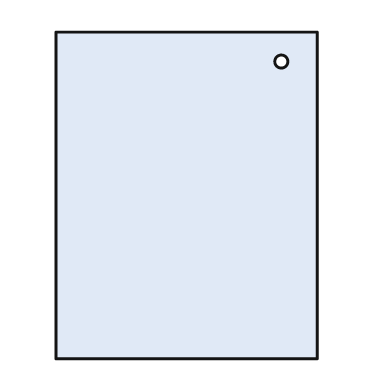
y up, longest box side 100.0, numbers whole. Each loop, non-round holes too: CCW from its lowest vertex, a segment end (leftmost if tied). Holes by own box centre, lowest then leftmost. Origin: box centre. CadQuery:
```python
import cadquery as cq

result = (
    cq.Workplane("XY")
    .moveTo(-40.0, -50.0)
    .lineTo(40.0, -50.0)
    .lineTo(40.0, 50.0)
    .lineTo(-40.0, 50.0)
    .close()
    .moveTo(29.0, 41.0)
    .circle(2.0)
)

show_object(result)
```